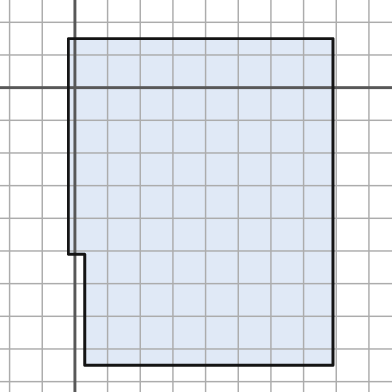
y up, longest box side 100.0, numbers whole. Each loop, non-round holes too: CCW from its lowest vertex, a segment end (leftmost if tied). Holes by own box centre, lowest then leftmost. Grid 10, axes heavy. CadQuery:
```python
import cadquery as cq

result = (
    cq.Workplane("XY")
    .moveTo(3.0, -85.0)
    .lineTo(79.0, -85.0)
    .lineTo(79.0, 15.0)
    .lineTo(-2.0, 15.0)
    .lineTo(-2.0, -51.0)
    .lineTo(3.0, -51.0)
    .close()
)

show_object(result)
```